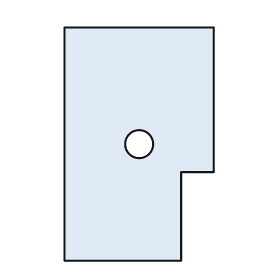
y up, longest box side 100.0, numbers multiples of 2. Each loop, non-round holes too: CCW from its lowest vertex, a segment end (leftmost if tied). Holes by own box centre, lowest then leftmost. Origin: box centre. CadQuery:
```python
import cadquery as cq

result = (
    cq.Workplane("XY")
    .moveTo(-32.0, -50.0)
    .lineTo(18.0, -50.0)
    .lineTo(18.0, -12.0)
    .lineTo(32.0, -12.0)
    .lineTo(32.0, 50.0)
    .lineTo(-32.0, 50.0)
    .close()
    .moveTo(0.0, 0.0)
    .circle(6.0)
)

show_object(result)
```